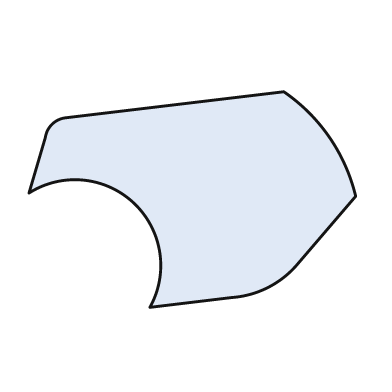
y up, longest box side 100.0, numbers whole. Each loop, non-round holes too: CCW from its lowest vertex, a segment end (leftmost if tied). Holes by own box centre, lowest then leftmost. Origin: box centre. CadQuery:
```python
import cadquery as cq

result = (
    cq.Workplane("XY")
    .moveTo(-13.0, -33.0)
    .lineTo(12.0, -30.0)
    .threePointArc((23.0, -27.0), (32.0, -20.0))
    .lineTo(50.0, 1.0)
    .threePointArc((42.0, 19.0), (28.0, 33.0))
    .lineTo(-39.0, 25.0)
    .threePointArc((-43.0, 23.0), (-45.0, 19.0))
    .lineTo(-50.0, 2.0)
    .threePointArc((-18.0, -1.0), (-13.0, -33.0))
    .close()
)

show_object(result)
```